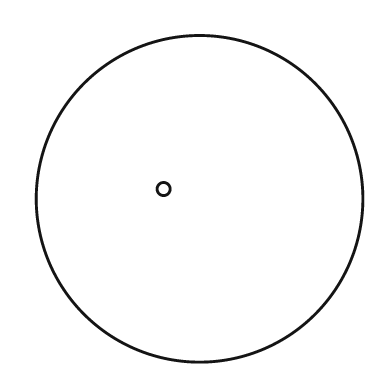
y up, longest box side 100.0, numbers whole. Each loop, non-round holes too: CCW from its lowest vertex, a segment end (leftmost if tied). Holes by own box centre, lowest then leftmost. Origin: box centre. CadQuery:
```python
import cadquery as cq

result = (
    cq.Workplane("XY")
    .moveTo(0.0, 0.0)
    .circle(50.0)
    .moveTo(-11.0, 3.0)
    .circle(2.0)
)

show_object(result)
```